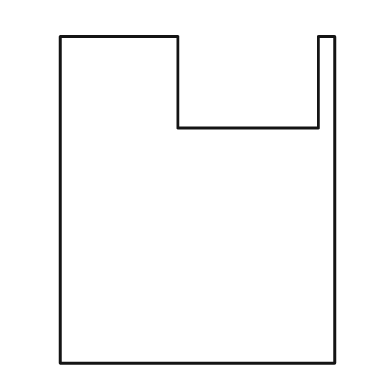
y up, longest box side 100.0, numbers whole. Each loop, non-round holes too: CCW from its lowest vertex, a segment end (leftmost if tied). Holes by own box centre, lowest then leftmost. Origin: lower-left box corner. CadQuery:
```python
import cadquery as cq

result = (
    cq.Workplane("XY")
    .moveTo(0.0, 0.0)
    .lineTo(84.0, 0.0)
    .lineTo(84.0, 100.0)
    .lineTo(79.0, 100.0)
    .lineTo(79.0, 72.0)
    .lineTo(36.0, 72.0)
    .lineTo(36.0, 100.0)
    .lineTo(0.0, 100.0)
    .close()
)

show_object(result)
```